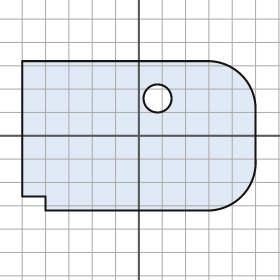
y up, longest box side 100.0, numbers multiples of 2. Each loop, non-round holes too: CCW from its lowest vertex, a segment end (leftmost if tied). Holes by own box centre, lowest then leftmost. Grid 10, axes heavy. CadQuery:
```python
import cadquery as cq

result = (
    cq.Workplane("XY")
    .moveTo(-40.0, -32.0)
    .lineTo(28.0, -32.0)
    .threePointArc((44.0, -26.0), (50.0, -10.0))
    .lineTo(50.0, 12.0)
    .threePointArc((44.0, 26.0), (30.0, 32.0))
    .lineTo(-50.0, 32.0)
    .lineTo(-50.0, -26.0)
    .lineTo(-40.0, -26.0)
    .close()
    .moveTo(8.0, 16.0)
    .circle(6.0)
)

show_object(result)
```